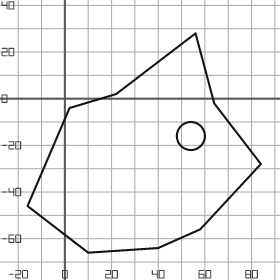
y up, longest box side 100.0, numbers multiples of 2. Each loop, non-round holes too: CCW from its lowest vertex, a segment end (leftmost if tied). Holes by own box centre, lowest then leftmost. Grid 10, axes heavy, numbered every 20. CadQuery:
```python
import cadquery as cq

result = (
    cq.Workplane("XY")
    .moveTo(10.0, -66.0)
    .lineTo(40.0, -64.0)
    .lineTo(58.0, -56.0)
    .lineTo(84.0, -28.0)
    .lineTo(64.0, -2.0)
    .lineTo(56.0, 28.0)
    .lineTo(22.0, 2.0)
    .lineTo(2.0, -4.0)
    .lineTo(-16.0, -46.0)
    .close()
    .moveTo(54.0, -16.0)
    .circle(6.0)
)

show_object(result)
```